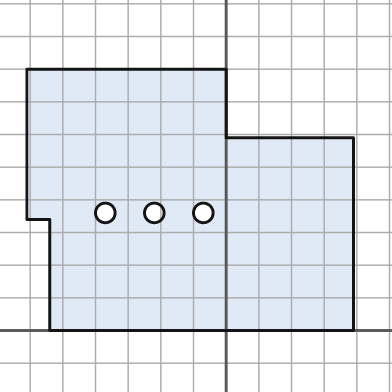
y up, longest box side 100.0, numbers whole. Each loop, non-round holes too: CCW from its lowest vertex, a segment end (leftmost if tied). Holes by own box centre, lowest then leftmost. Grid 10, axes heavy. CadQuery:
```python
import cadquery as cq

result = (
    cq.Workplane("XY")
    .moveTo(-54.0, 0.0)
    .lineTo(39.0, 0.0)
    .lineTo(39.0, 59.0)
    .lineTo(0.0, 59.0)
    .lineTo(0.0, 80.0)
    .lineTo(-61.0, 80.0)
    .lineTo(-61.0, 34.0)
    .lineTo(-54.0, 34.0)
    .close()
    .moveTo(-37.0, 36.0)
    .circle(3.0)
    .moveTo(-22.0, 36.0)
    .circle(3.0)
    .moveTo(-7.0, 36.0)
    .circle(3.0)
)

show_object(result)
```